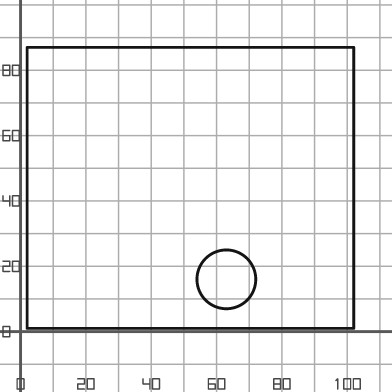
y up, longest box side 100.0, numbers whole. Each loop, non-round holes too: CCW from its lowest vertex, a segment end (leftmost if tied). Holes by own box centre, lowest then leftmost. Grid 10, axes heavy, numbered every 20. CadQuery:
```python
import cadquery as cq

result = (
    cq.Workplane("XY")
    .moveTo(2.0, 1.0)
    .lineTo(102.0, 1.0)
    .lineTo(102.0, 87.0)
    .lineTo(2.0, 87.0)
    .close()
    .moveTo(63.0, 16.0)
    .circle(9.0)
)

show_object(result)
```